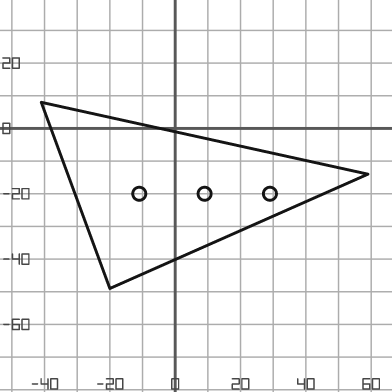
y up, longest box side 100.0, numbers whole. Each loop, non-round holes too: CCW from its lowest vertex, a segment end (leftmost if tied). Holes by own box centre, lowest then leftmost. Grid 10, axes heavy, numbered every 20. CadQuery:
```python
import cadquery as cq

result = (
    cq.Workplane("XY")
    .moveTo(-20.0, -49.0)
    .lineTo(59.0, -14.0)
    .lineTo(-41.0, 8.0)
    .close()
    .moveTo(-11.0, -20.0)
    .circle(2.0)
    .moveTo(9.0, -20.0)
    .circle(2.0)
    .moveTo(29.0, -20.0)
    .circle(2.0)
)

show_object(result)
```